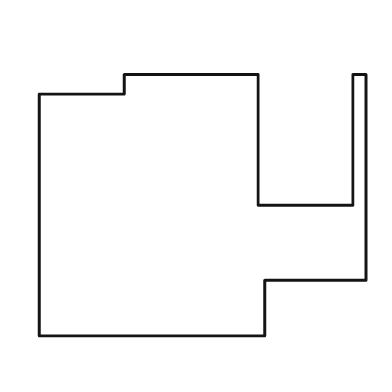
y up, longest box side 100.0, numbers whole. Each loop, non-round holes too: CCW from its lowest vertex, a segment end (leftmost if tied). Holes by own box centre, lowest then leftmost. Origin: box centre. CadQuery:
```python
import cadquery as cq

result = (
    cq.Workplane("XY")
    .moveTo(-50.0, -40.0)
    .lineTo(19.0, -40.0)
    .lineTo(19.0, -23.0)
    .lineTo(50.0, -23.0)
    .lineTo(50.0, 40.0)
    .lineTo(46.0, 40.0)
    .lineTo(46.0, 0.0)
    .lineTo(17.0, 0.0)
    .lineTo(17.0, 40.0)
    .lineTo(-24.0, 40.0)
    .lineTo(-24.0, 34.0)
    .lineTo(-50.0, 34.0)
    .close()
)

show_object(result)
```